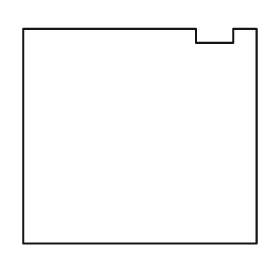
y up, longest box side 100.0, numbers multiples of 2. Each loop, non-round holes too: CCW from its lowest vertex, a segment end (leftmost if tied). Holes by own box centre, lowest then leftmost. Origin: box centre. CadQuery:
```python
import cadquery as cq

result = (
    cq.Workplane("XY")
    .moveTo(-50.0, -46.0)
    .lineTo(50.0, -46.0)
    .lineTo(50.0, 46.0)
    .lineTo(40.0, 46.0)
    .lineTo(40.0, 40.0)
    .lineTo(24.0, 40.0)
    .lineTo(24.0, 46.0)
    .lineTo(-50.0, 46.0)
    .close()
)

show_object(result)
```